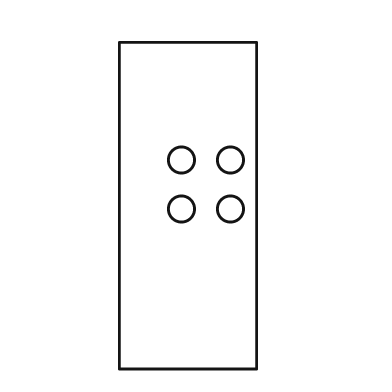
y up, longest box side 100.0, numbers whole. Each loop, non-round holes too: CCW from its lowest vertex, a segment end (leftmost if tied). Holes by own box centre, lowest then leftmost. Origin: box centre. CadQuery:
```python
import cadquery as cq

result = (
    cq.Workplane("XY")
    .moveTo(-21.0, -50.0)
    .lineTo(21.0, -50.0)
    .lineTo(21.0, 50.0)
    .lineTo(-21.0, 50.0)
    .close()
    .moveTo(-2.0, -1.0)
    .circle(4.0)
    .moveTo(13.0, -1.0)
    .circle(4.0)
    .moveTo(-2.0, 14.0)
    .circle(4.0)
    .moveTo(13.0, 14.0)
    .circle(4.0)
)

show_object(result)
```